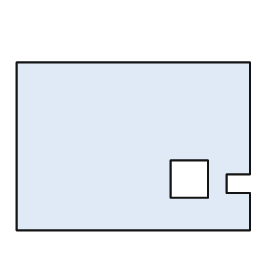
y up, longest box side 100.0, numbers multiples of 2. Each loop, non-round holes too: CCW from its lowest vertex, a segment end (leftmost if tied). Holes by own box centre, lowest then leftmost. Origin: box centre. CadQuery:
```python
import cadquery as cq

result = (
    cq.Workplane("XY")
    .moveTo(-50.0, -36.0)
    .lineTo(50.0, -36.0)
    .lineTo(50.0, -20.0)
    .lineTo(40.0, -20.0)
    .lineTo(40.0, -12.0)
    .lineTo(50.0, -12.0)
    .lineTo(50.0, 36.0)
    .lineTo(-50.0, 36.0)
    .close()
    .moveTo(16.0, -22.0)
    .lineTo(32.0, -22.0)
    .lineTo(32.0, -6.0)
    .lineTo(16.0, -6.0)
    .close()
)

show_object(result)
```